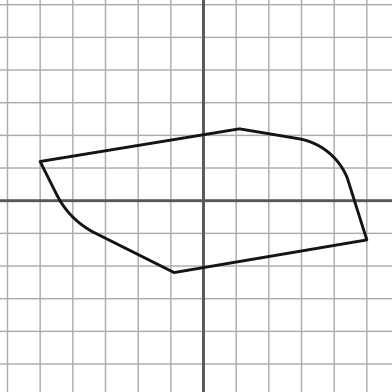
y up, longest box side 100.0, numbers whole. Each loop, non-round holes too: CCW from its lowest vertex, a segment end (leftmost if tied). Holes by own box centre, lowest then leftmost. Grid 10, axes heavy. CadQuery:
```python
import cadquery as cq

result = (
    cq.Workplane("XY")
    .moveTo(-9.0, -22.0)
    .lineTo(50.0, -12.0)
    .lineTo(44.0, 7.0)
    .threePointArc((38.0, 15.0), (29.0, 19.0))
    .lineTo(11.0, 22.0)
    .lineTo(-50.0, 12.0)
    .lineTo(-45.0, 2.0)
    .threePointArc((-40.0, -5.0), (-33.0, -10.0))
    .close()
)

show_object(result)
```